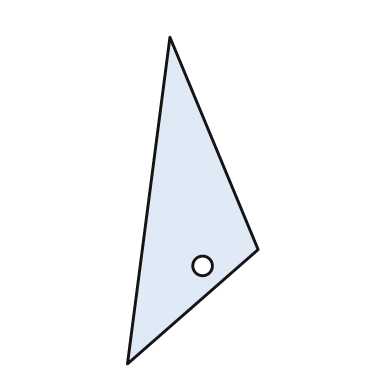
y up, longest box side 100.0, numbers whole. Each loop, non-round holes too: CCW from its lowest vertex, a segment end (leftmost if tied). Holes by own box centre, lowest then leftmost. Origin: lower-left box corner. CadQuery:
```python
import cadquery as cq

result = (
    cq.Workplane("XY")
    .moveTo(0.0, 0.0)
    .lineTo(40.0, 35.0)
    .lineTo(13.0, 100.0)
    .close()
    .moveTo(23.0, 30.0)
    .circle(3.0)
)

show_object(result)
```